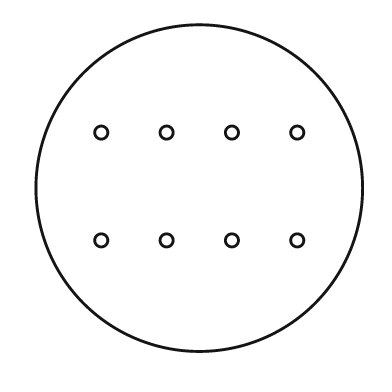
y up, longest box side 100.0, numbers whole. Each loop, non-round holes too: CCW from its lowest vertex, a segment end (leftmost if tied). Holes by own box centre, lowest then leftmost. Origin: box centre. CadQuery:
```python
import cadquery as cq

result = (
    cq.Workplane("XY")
    .moveTo(0.0, 0.0)
    .circle(50.0)
    .moveTo(-30.0, -16.0)
    .circle(2.0)
    .moveTo(-10.0, -16.0)
    .circle(2.0)
    .moveTo(10.0, -16.0)
    .circle(2.0)
    .moveTo(30.0, -16.0)
    .circle(2.0)
    .moveTo(-30.0, 17.0)
    .circle(2.0)
    .moveTo(-10.0, 17.0)
    .circle(2.0)
    .moveTo(10.0, 17.0)
    .circle(2.0)
    .moveTo(30.0, 17.0)
    .circle(2.0)
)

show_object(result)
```